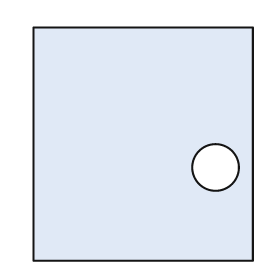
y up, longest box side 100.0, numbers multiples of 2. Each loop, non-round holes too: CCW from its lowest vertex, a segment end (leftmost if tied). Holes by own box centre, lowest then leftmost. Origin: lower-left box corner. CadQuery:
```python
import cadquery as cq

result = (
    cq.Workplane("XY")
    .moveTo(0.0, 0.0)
    .lineTo(94.0, 0.0)
    .lineTo(94.0, 100.0)
    .lineTo(0.0, 100.0)
    .close()
    .moveTo(78.0, 40.0)
    .circle(10.0)
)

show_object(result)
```